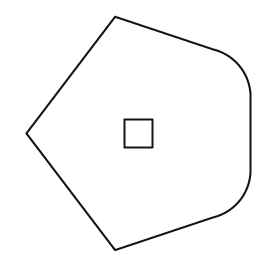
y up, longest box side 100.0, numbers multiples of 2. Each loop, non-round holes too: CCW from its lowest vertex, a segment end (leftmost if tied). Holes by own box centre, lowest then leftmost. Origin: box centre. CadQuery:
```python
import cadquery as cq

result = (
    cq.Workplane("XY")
    .moveTo(-10.0, -50.0)
    .lineTo(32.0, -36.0)
    .threePointArc((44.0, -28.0), (48.0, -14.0))
    .lineTo(48.0, 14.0)
    .threePointArc((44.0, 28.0), (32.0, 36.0))
    .lineTo(-10.0, 50.0)
    .lineTo(-48.0, 0.0)
    .close()
    .moveTo(-6.0, -6.0)
    .lineTo(6.0, -6.0)
    .lineTo(6.0, 6.0)
    .lineTo(-6.0, 6.0)
    .close()
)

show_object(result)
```